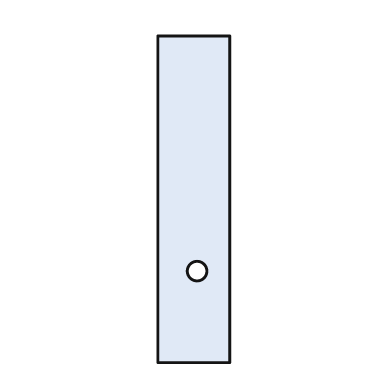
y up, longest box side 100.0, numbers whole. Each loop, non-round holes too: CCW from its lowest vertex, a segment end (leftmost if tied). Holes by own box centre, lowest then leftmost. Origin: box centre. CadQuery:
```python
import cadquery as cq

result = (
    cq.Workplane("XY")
    .moveTo(-11.0, -50.0)
    .lineTo(11.0, -50.0)
    .lineTo(11.0, 50.0)
    .lineTo(-11.0, 50.0)
    .close()
    .moveTo(1.0, -22.0)
    .circle(3.0)
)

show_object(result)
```